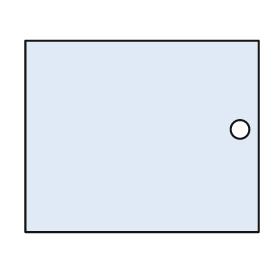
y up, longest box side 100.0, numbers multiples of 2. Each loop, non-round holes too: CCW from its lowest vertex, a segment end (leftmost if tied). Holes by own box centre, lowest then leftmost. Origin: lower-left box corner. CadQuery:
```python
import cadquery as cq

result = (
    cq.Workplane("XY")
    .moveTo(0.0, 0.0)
    .lineTo(100.0, 0.0)
    .lineTo(100.0, 82.0)
    .lineTo(0.0, 82.0)
    .close()
    .moveTo(92.0, 44.0)
    .circle(4.0)
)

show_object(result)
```